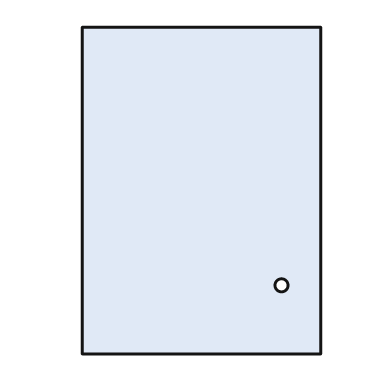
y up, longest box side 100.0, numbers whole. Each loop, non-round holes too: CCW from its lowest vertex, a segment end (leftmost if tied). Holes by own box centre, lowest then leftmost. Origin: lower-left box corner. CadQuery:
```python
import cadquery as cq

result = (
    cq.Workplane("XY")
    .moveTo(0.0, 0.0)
    .lineTo(73.0, 0.0)
    .lineTo(73.0, 100.0)
    .lineTo(0.0, 100.0)
    .close()
    .moveTo(61.0, 21.0)
    .circle(2.0)
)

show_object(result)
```